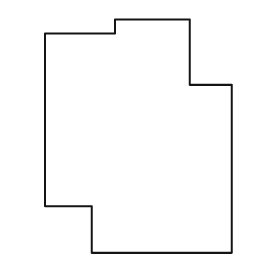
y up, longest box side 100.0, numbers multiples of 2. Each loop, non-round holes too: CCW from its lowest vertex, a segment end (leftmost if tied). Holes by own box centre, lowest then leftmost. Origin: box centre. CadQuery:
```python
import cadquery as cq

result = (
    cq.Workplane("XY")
    .moveTo(-20.0, -50.0)
    .lineTo(40.0, -50.0)
    .lineTo(40.0, 22.0)
    .lineTo(22.0, 22.0)
    .lineTo(22.0, 50.0)
    .lineTo(-10.0, 50.0)
    .lineTo(-10.0, 44.0)
    .lineTo(-40.0, 44.0)
    .lineTo(-40.0, -30.0)
    .lineTo(-20.0, -30.0)
    .close()
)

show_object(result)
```